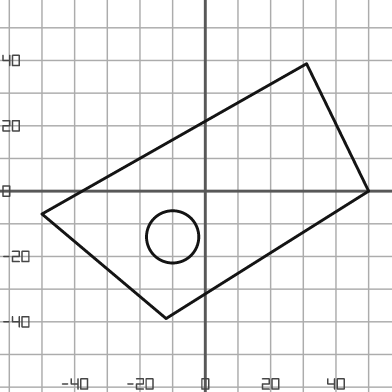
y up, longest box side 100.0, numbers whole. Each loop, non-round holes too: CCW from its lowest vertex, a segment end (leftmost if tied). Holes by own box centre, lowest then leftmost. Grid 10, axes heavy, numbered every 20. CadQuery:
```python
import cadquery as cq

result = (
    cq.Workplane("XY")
    .moveTo(-12.0, -39.0)
    .lineTo(50.0, 0.0)
    .lineTo(31.0, 39.0)
    .lineTo(-50.0, -7.0)
    .close()
    .moveTo(-10.0, -14.0)
    .circle(8.0)
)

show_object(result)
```